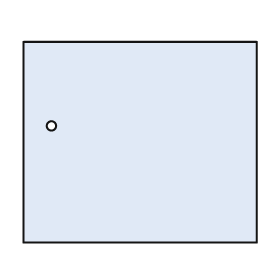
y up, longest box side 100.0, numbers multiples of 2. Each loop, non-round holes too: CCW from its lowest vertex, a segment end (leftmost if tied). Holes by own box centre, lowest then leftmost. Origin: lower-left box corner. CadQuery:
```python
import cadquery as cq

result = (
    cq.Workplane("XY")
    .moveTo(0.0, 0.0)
    .lineTo(100.0, 0.0)
    .lineTo(100.0, 86.0)
    .lineTo(0.0, 86.0)
    .close()
    .moveTo(12.0, 50.0)
    .circle(2.0)
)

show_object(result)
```